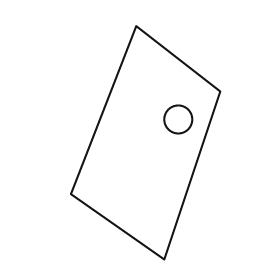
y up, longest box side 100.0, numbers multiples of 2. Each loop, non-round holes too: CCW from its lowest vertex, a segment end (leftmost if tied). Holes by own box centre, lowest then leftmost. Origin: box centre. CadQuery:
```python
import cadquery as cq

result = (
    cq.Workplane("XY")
    .moveTo(8.0, -50.0)
    .lineTo(32.0, 22.0)
    .lineTo(-4.0, 50.0)
    .lineTo(-32.0, -22.0)
    .close()
    .moveTo(14.0, 10.0)
    .circle(6.0)
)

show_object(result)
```